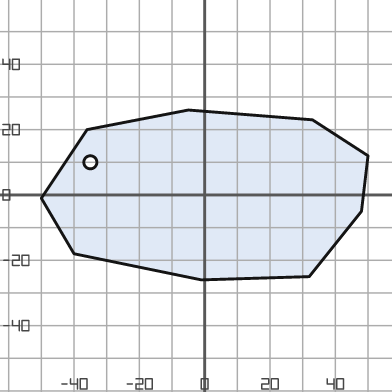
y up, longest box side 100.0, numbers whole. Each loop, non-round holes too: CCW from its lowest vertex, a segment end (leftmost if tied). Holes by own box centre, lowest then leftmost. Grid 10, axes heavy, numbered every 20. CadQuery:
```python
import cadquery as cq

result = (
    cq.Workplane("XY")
    .moveTo(-1.0, -26.0)
    .lineTo(32.0, -25.0)
    .lineTo(48.0, -5.0)
    .lineTo(50.0, 12.0)
    .lineTo(33.0, 23.0)
    .lineTo(-5.0, 26.0)
    .lineTo(-36.0, 20.0)
    .lineTo(-50.0, -1.0)
    .lineTo(-40.0, -18.0)
    .close()
    .moveTo(-35.0, 10.0)
    .circle(2.0)
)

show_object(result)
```